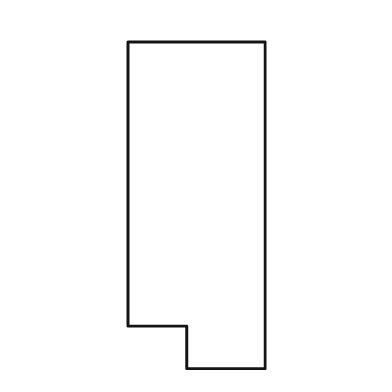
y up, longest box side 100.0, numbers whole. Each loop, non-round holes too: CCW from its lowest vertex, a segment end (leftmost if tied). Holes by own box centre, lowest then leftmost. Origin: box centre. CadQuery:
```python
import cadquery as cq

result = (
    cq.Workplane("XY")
    .moveTo(-3.0, -50.0)
    .lineTo(21.0, -50.0)
    .lineTo(21.0, 50.0)
    .lineTo(-21.0, 50.0)
    .lineTo(-21.0, -37.0)
    .lineTo(-3.0, -37.0)
    .close()
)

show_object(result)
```